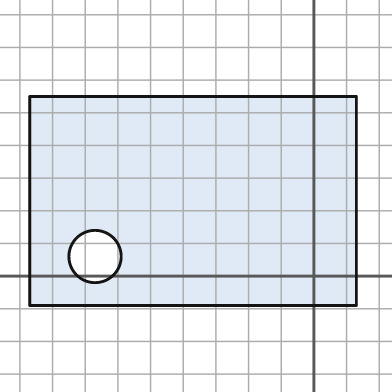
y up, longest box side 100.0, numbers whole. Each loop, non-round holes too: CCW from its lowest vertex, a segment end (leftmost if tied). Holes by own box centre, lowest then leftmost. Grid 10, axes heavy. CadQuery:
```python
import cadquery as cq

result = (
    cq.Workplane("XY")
    .moveTo(-87.0, -9.0)
    .lineTo(13.0, -9.0)
    .lineTo(13.0, 55.0)
    .lineTo(-87.0, 55.0)
    .close()
    .moveTo(-67.0, 6.0)
    .circle(8.0)
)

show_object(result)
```